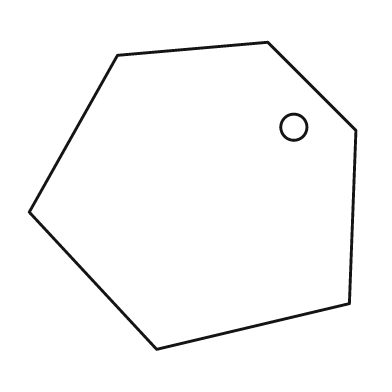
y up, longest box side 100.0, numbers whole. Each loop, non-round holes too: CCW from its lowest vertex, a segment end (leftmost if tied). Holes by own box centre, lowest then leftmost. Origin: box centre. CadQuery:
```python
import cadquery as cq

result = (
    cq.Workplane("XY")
    .moveTo(-11.0, -47.0)
    .lineTo(48.0, -33.0)
    .lineTo(50.0, 20.0)
    .lineTo(23.0, 47.0)
    .lineTo(-23.0, 43.0)
    .lineTo(-50.0, -5.0)
    .close()
    .moveTo(31.0, 21.0)
    .circle(4.0)
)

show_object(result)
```